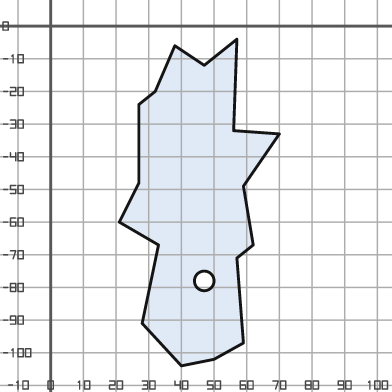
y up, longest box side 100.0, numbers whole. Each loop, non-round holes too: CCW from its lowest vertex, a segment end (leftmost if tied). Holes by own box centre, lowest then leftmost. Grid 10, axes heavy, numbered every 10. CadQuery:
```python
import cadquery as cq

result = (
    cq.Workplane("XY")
    .moveTo(40.0, -104.0)
    .lineTo(50.0, -102.0)
    .lineTo(59.0, -97.0)
    .lineTo(57.0, -71.0)
    .lineTo(62.0, -67.0)
    .lineTo(59.0, -49.0)
    .lineTo(70.0, -33.0)
    .lineTo(56.0, -32.0)
    .lineTo(57.0, -4.0)
    .lineTo(47.0, -12.0)
    .lineTo(38.0, -6.0)
    .lineTo(32.0, -20.0)
    .lineTo(27.0, -24.0)
    .lineTo(27.0, -48.0)
    .lineTo(21.0, -60.0)
    .lineTo(33.0, -67.0)
    .lineTo(28.0, -91.0)
    .close()
    .moveTo(47.0, -78.0)
    .circle(3.0)
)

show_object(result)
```